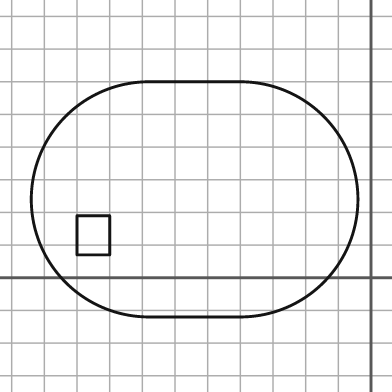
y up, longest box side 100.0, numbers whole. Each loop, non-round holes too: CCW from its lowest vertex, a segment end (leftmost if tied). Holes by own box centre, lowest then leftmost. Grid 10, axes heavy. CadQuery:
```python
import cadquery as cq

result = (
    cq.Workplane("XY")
    .moveTo(-68.0, -12.0)
    .lineTo(-40.0, -12.0)
    .threePointArc((-4.0, 24.0), (-40.0, 60.0))
    .lineTo(-68.0, 60.0)
    .threePointArc((-104.0, 24.0), (-68.0, -12.0))
    .close()
    .moveTo(-90.0, 7.0)
    .lineTo(-80.0, 7.0)
    .lineTo(-80.0, 19.0)
    .lineTo(-90.0, 19.0)
    .close()
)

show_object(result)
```